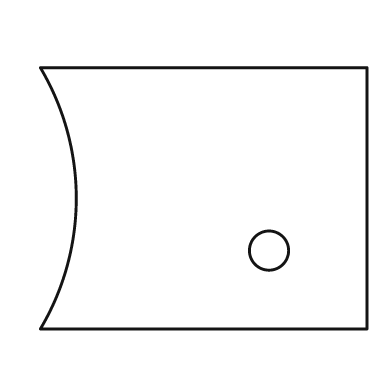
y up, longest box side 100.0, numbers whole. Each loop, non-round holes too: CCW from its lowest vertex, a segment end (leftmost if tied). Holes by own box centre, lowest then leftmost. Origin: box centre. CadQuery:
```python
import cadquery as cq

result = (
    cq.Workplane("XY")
    .moveTo(-50.0, -40.0)
    .lineTo(50.0, -40.0)
    .lineTo(50.0, 40.0)
    .lineTo(-50.0, 40.0)
    .threePointArc((-39.0, 0.0), (-50.0, -40.0))
    .close()
    .moveTo(20.0, -16.0)
    .circle(6.0)
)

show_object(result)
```